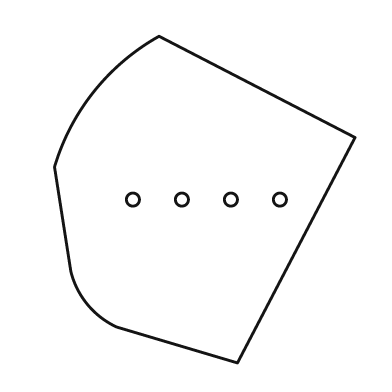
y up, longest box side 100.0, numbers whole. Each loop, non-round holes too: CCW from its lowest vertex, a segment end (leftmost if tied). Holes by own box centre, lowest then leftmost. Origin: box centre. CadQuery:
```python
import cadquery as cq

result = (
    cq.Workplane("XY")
    .moveTo(10.0, -50.0)
    .lineTo(46.0, 19.0)
    .lineTo(-14.0, 50.0)
    .threePointArc((-34.0, 33.0), (-46.0, 10.0))
    .lineTo(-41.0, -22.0)
    .threePointArc((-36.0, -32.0), (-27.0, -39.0))
    .close()
    .moveTo(-22.0, 0.0)
    .circle(2.0)
    .moveTo(-7.0, 0.0)
    .circle(2.0)
    .moveTo(8.0, 0.0)
    .circle(2.0)
    .moveTo(23.0, 0.0)
    .circle(2.0)
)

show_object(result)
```